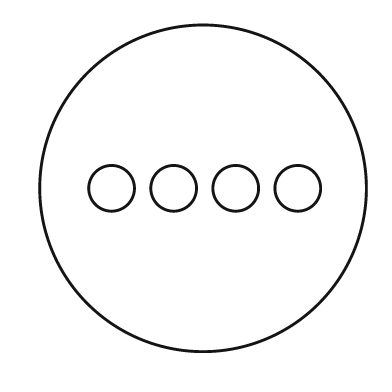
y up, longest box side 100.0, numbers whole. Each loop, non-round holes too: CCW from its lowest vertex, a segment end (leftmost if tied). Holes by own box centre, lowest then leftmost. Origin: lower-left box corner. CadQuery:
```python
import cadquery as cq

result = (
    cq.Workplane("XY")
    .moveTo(50.0, 50.0)
    .circle(50.0)
    .moveTo(22.0, 50.0)
    .circle(7.0)
    .moveTo(41.0, 50.0)
    .circle(7.0)
    .moveTo(60.0, 50.0)
    .circle(7.0)
    .moveTo(79.0, 50.0)
    .circle(7.0)
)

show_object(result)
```